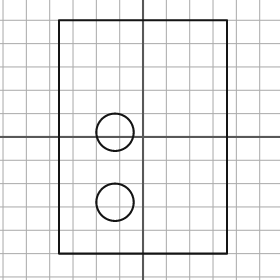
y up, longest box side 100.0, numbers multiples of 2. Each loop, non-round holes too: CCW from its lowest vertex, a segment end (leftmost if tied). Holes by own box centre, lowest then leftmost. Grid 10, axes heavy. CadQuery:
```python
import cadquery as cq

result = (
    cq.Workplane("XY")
    .moveTo(-36.0, -50.0)
    .lineTo(36.0, -50.0)
    .lineTo(36.0, 50.0)
    .lineTo(-36.0, 50.0)
    .close()
    .moveTo(-12.0, -28.0)
    .circle(8.0)
    .moveTo(-12.0, 2.0)
    .circle(8.0)
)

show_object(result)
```